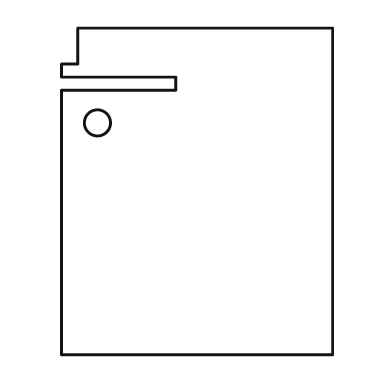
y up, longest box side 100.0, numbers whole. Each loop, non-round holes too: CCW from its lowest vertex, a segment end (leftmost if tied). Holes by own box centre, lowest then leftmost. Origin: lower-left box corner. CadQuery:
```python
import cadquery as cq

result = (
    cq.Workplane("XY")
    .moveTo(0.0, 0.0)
    .lineTo(83.0, 0.0)
    .lineTo(83.0, 100.0)
    .lineTo(5.0, 100.0)
    .lineTo(5.0, 89.0)
    .lineTo(0.0, 89.0)
    .lineTo(0.0, 85.0)
    .lineTo(35.0, 85.0)
    .lineTo(35.0, 81.0)
    .lineTo(0.0, 81.0)
    .close()
    .moveTo(11.0, 71.0)
    .circle(4.0)
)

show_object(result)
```